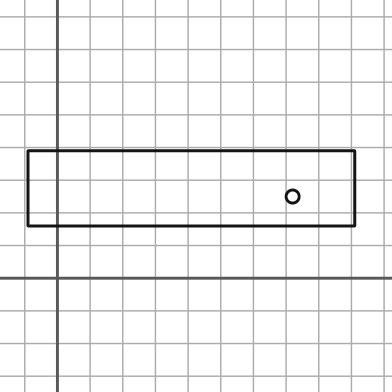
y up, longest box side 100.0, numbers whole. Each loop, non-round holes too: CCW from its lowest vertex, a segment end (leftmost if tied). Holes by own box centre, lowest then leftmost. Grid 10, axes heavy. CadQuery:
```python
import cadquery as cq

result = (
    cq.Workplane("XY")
    .moveTo(-9.0, 16.0)
    .lineTo(91.0, 16.0)
    .lineTo(91.0, 39.0)
    .lineTo(-9.0, 39.0)
    .close()
    .moveTo(72.0, 25.0)
    .circle(2.0)
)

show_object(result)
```